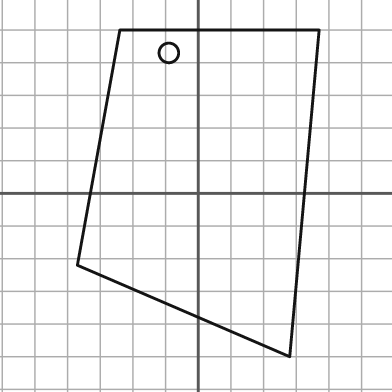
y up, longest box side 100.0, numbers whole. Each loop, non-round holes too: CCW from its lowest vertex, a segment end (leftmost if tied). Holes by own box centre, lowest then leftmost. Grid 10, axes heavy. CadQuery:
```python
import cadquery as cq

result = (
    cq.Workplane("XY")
    .moveTo(28.0, -50.0)
    .lineTo(37.0, 50.0)
    .lineTo(-24.0, 50.0)
    .lineTo(-37.0, -22.0)
    .close()
    .moveTo(-9.0, 43.0)
    .circle(3.0)
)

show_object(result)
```